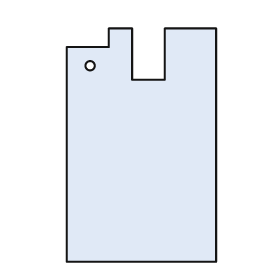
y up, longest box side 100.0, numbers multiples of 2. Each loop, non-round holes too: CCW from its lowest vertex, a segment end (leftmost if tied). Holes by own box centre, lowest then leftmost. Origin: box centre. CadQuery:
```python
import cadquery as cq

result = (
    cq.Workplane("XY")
    .moveTo(-32.0, -50.0)
    .lineTo(32.0, -50.0)
    .lineTo(32.0, 50.0)
    .lineTo(10.0, 50.0)
    .lineTo(10.0, 28.0)
    .lineTo(-4.0, 28.0)
    .lineTo(-4.0, 50.0)
    .lineTo(-14.0, 50.0)
    .lineTo(-14.0, 42.0)
    .lineTo(-32.0, 42.0)
    .close()
    .moveTo(-22.0, 34.0)
    .circle(2.0)
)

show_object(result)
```